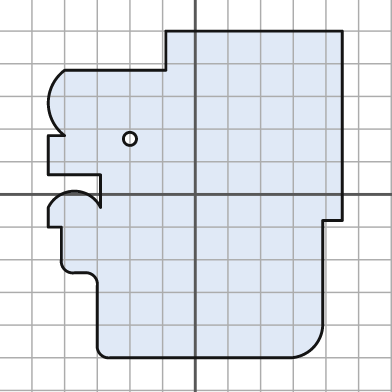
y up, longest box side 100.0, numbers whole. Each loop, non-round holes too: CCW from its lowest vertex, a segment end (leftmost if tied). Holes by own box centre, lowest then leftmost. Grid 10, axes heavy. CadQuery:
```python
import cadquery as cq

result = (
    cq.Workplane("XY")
    .moveTo(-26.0, -50.0)
    .lineTo(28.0, -50.0)
    .threePointArc((36.0, -47.0), (39.0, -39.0))
    .lineTo(39.0, -8.0)
    .lineTo(45.0, -8.0)
    .lineTo(45.0, 50.0)
    .lineTo(-9.0, 50.0)
    .lineTo(-9.0, 38.0)
    .lineTo(-40.0, 38.0)
    .threePointArc((-45.0, 28.0), (-40.0, 18.0))
    .lineTo(-45.0, 18.0)
    .lineTo(-45.0, 6.0)
    .lineTo(-29.0, 6.0)
    .lineTo(-29.0, -4.0)
    .threePointArc((-37.0, 1.0), (-45.0, -4.0))
    .lineTo(-45.0, -10.0)
    .lineTo(-41.0, -10.0)
    .lineTo(-41.0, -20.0)
    .threePointArc((-40.0, -23.0), (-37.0, -24.0))
    .lineTo(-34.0, -24.0)
    .threePointArc((-31.0, -25.0), (-30.0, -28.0))
    .lineTo(-30.0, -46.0)
    .threePointArc((-29.0, -49.0), (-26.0, -50.0))
    .close()
    .moveTo(-20.0, 17.0)
    .circle(2.0)
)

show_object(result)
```